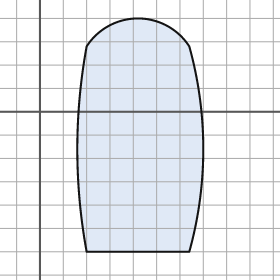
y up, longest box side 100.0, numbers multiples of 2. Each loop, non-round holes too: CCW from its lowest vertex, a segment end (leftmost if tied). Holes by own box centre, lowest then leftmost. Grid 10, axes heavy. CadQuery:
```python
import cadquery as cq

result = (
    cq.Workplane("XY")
    .moveTo(20.0, -60.0)
    .lineTo(64.0, -60.0)
    .threePointArc((70.0, -16.0), (64.0, 28.0))
    .threePointArc((42.0, 40.0), (20.0, 28.0))
    .threePointArc((16.0, -16.0), (20.0, -60.0))
    .close()
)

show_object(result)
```